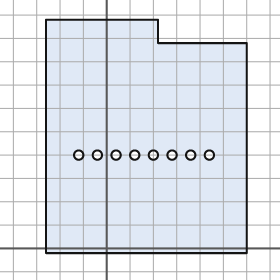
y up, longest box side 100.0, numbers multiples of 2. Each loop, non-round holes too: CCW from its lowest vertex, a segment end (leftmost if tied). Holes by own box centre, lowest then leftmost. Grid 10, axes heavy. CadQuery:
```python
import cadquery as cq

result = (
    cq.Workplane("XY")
    .moveTo(-26.0, -2.0)
    .lineTo(60.0, -2.0)
    .lineTo(60.0, 88.0)
    .lineTo(22.0, 88.0)
    .lineTo(22.0, 98.0)
    .lineTo(-26.0, 98.0)
    .close()
    .moveTo(-12.0, 40.0)
    .circle(2.0)
    .moveTo(-4.0, 40.0)
    .circle(2.0)
    .moveTo(4.0, 40.0)
    .circle(2.0)
    .moveTo(12.0, 40.0)
    .circle(2.0)
    .moveTo(20.0, 40.0)
    .circle(2.0)
    .moveTo(28.0, 40.0)
    .circle(2.0)
    .moveTo(36.0, 40.0)
    .circle(2.0)
    .moveTo(44.0, 40.0)
    .circle(2.0)
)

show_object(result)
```